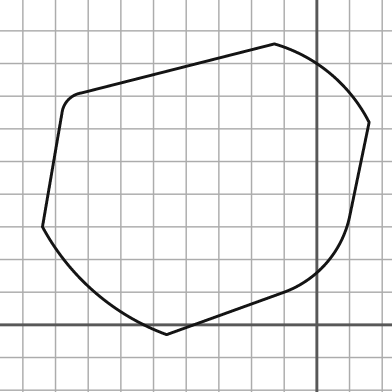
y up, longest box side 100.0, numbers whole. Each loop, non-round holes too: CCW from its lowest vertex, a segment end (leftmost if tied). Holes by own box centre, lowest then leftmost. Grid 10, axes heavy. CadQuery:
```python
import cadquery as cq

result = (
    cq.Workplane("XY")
    .moveTo(-46.0, -3.0)
    .lineTo(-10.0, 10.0)
    .threePointArc((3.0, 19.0), (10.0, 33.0))
    .lineTo(16.0, 62.0)
    .threePointArc((4.0, 77.0), (-13.0, 86.0))
    .lineTo(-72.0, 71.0)
    .threePointArc((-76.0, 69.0), (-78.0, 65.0))
    .lineTo(-84.0, 30.0)
    .threePointArc((-68.0, 10.0), (-46.0, -3.0))
    .close()
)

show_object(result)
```